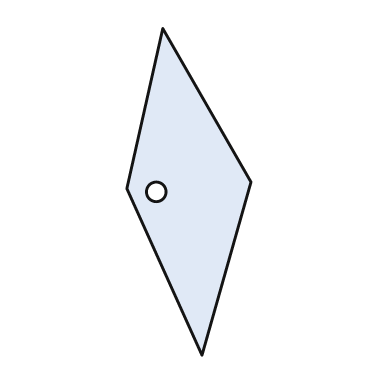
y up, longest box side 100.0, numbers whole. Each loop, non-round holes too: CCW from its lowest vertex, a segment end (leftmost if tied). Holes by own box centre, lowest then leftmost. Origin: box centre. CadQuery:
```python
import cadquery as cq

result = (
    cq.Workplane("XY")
    .moveTo(4.0, -50.0)
    .lineTo(19.0, 3.0)
    .lineTo(-8.0, 50.0)
    .lineTo(-19.0, 1.0)
    .close()
    .moveTo(-10.0, 0.0)
    .circle(3.0)
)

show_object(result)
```